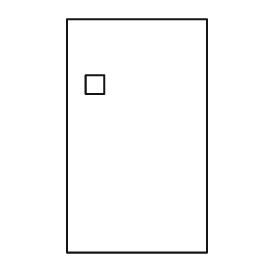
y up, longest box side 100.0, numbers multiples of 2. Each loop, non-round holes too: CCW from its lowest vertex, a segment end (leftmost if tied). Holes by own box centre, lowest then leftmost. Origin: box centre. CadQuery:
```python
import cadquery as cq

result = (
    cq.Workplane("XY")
    .moveTo(-30.0, -50.0)
    .lineTo(30.0, -50.0)
    .lineTo(30.0, 50.0)
    .lineTo(-30.0, 50.0)
    .close()
    .moveTo(-22.0, 18.0)
    .lineTo(-14.0, 18.0)
    .lineTo(-14.0, 26.0)
    .lineTo(-22.0, 26.0)
    .close()
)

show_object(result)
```